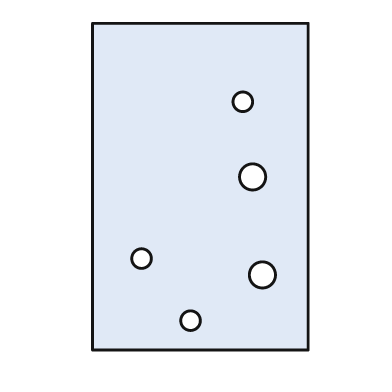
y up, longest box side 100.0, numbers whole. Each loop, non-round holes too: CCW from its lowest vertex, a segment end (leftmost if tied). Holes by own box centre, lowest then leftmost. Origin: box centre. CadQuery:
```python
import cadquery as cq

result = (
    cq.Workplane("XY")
    .moveTo(-33.0, -50.0)
    .lineTo(33.0, -50.0)
    .lineTo(33.0, 50.0)
    .lineTo(-33.0, 50.0)
    .close()
    .moveTo(-3.0, -41.0)
    .circle(3.0)
    .moveTo(19.0, -27.0)
    .circle(4.0)
    .moveTo(-18.0, -22.0)
    .circle(3.0)
    .moveTo(16.0, 3.0)
    .circle(4.0)
    .moveTo(13.0, 26.0)
    .circle(3.0)
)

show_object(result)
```